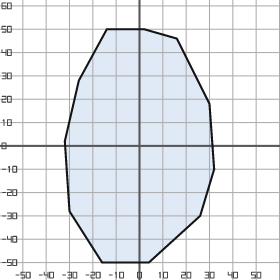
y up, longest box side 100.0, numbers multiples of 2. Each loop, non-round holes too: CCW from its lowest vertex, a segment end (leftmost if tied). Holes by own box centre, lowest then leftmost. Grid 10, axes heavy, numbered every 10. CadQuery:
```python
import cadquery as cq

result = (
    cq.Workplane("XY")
    .moveTo(-16.0, -50.0)
    .lineTo(4.0, -50.0)
    .lineTo(26.0, -30.0)
    .lineTo(32.0, -10.0)
    .lineTo(30.0, 18.0)
    .lineTo(16.0, 46.0)
    .lineTo(2.0, 50.0)
    .lineTo(-14.0, 50.0)
    .lineTo(-26.0, 28.0)
    .lineTo(-32.0, 2.0)
    .lineTo(-30.0, -28.0)
    .close()
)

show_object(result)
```